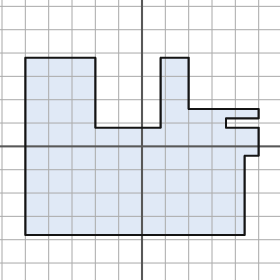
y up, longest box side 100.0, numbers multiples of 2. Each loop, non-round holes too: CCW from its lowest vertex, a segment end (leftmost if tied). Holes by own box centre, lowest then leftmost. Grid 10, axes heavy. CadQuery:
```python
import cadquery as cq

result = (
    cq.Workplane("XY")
    .moveTo(-50.0, -38.0)
    .lineTo(44.0, -38.0)
    .lineTo(44.0, -4.0)
    .lineTo(50.0, -4.0)
    .lineTo(50.0, 8.0)
    .lineTo(36.0, 8.0)
    .lineTo(36.0, 12.0)
    .lineTo(50.0, 12.0)
    .lineTo(50.0, 16.0)
    .lineTo(20.0, 16.0)
    .lineTo(20.0, 38.0)
    .lineTo(8.0, 38.0)
    .lineTo(8.0, 8.0)
    .lineTo(-20.0, 8.0)
    .lineTo(-20.0, 38.0)
    .lineTo(-50.0, 38.0)
    .close()
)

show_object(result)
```